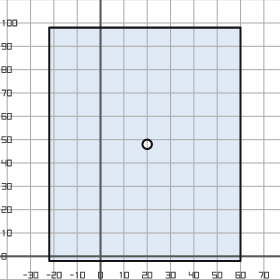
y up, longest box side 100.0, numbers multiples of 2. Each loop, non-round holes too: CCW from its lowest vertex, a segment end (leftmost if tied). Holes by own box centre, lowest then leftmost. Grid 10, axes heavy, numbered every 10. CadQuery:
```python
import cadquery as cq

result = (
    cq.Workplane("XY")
    .moveTo(-22.0, -2.0)
    .lineTo(60.0, -2.0)
    .lineTo(60.0, 98.0)
    .lineTo(-22.0, 98.0)
    .close()
    .moveTo(20.0, 48.0)
    .circle(2.0)
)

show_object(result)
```